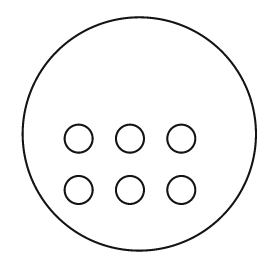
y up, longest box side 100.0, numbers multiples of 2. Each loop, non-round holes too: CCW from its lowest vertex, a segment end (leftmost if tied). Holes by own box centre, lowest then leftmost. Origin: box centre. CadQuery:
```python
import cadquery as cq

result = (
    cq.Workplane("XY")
    .moveTo(0.0, 0.0)
    .circle(50.0)
    .moveTo(-26.0, -24.0)
    .circle(6.0)
    .moveTo(-4.0, -24.0)
    .circle(6.0)
    .moveTo(18.0, -24.0)
    .circle(6.0)
    .moveTo(-26.0, -2.0)
    .circle(6.0)
    .moveTo(-4.0, -2.0)
    .circle(6.0)
    .moveTo(18.0, -2.0)
    .circle(6.0)
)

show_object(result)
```